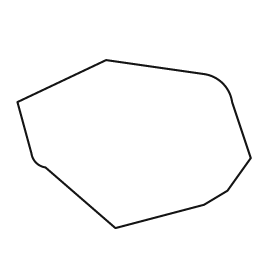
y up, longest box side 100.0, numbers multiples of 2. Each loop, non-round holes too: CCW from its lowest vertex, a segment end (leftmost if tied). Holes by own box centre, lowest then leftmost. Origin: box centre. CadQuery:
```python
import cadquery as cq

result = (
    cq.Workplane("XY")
    .moveTo(-8.0, -36.0)
    .lineTo(30.0, -26.0)
    .lineTo(40.0, -20.0)
    .lineTo(50.0, -6.0)
    .lineTo(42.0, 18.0)
    .threePointArc((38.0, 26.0), (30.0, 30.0))
    .lineTo(-12.0, 36.0)
    .lineTo(-50.0, 18.0)
    .lineTo(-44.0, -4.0)
    .threePointArc((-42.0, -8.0), (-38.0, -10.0))
    .close()
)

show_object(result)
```